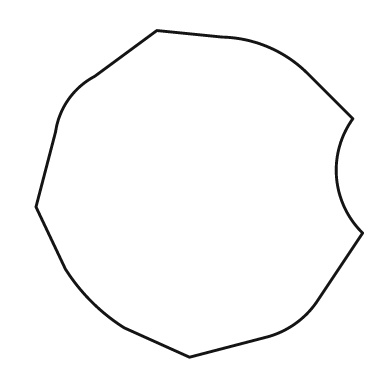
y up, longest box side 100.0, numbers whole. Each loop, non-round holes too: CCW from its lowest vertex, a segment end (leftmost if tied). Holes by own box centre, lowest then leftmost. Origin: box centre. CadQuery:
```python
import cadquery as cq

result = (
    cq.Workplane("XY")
    .moveTo(-3.0, -50.0)
    .lineTo(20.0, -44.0)
    .threePointArc((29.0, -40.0), (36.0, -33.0))
    .lineTo(50.0, -12.0)
    .threePointArc((42.0, 5.0), (47.0, 23.0))
    .lineTo(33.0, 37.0)
    .threePointArc((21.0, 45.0), (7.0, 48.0))
    .lineTo(-13.0, 50.0)
    .lineTo(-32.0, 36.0)
    .threePointArc((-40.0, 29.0), (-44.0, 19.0))
    .lineTo(-50.0, -4.0)
    .lineTo(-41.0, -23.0)
    .threePointArc((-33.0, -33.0), (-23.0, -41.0))
    .close()
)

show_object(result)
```